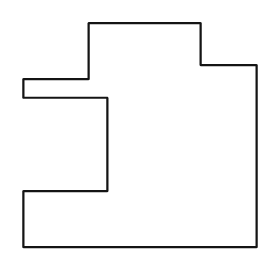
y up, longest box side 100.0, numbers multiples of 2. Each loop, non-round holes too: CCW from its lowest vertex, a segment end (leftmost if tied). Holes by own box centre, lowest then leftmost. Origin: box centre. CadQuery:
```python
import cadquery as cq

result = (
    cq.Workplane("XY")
    .moveTo(-50.0, -48.0)
    .lineTo(50.0, -48.0)
    .lineTo(50.0, 30.0)
    .lineTo(26.0, 30.0)
    .lineTo(26.0, 48.0)
    .lineTo(-22.0, 48.0)
    .lineTo(-22.0, 24.0)
    .lineTo(-50.0, 24.0)
    .lineTo(-50.0, 16.0)
    .lineTo(-14.0, 16.0)
    .lineTo(-14.0, -24.0)
    .lineTo(-50.0, -24.0)
    .close()
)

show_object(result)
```